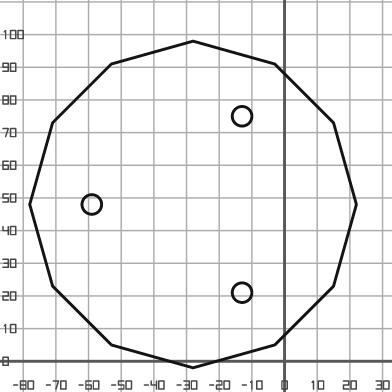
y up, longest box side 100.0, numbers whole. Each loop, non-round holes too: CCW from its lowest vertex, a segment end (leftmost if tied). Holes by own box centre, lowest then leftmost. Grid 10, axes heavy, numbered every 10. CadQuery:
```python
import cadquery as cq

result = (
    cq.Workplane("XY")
    .moveTo(-28.0, -2.0)
    .lineTo(-3.0, 5.0)
    .lineTo(15.0, 23.0)
    .lineTo(22.0, 48.0)
    .lineTo(15.0, 73.0)
    .lineTo(-3.0, 91.0)
    .lineTo(-28.0, 98.0)
    .lineTo(-53.0, 91.0)
    .lineTo(-71.0, 73.0)
    .lineTo(-78.0, 48.0)
    .lineTo(-71.0, 23.0)
    .lineTo(-53.0, 5.0)
    .close()
    .moveTo(-13.0, 21.0)
    .circle(3.0)
    .moveTo(-59.0, 48.0)
    .circle(3.0)
    .moveTo(-13.0, 75.0)
    .circle(3.0)
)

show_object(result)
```